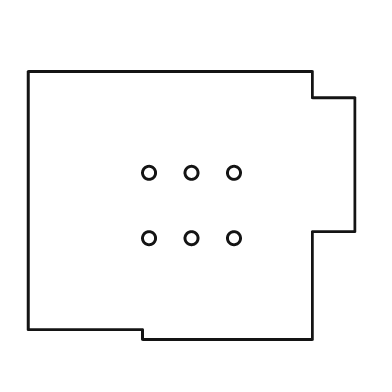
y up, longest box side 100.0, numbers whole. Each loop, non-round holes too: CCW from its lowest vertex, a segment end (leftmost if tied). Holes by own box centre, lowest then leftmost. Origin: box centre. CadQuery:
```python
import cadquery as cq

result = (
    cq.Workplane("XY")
    .moveTo(-15.0, -41.0)
    .lineTo(37.0, -41.0)
    .lineTo(37.0, -8.0)
    .lineTo(50.0, -8.0)
    .lineTo(50.0, 33.0)
    .lineTo(37.0, 33.0)
    .lineTo(37.0, 41.0)
    .lineTo(-50.0, 41.0)
    .lineTo(-50.0, -38.0)
    .lineTo(-15.0, -38.0)
    .close()
    .moveTo(-13.0, -10.0)
    .circle(2.0)
    .moveTo(0.0, -10.0)
    .circle(2.0)
    .moveTo(13.0, -10.0)
    .circle(2.0)
    .moveTo(-13.0, 10.0)
    .circle(2.0)
    .moveTo(0.0, 10.0)
    .circle(2.0)
    .moveTo(13.0, 10.0)
    .circle(2.0)
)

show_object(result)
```